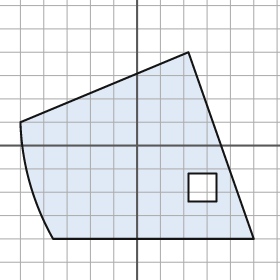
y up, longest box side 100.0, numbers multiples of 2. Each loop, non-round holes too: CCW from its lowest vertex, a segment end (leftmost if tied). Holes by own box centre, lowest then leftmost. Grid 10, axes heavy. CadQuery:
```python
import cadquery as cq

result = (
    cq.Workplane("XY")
    .moveTo(-36.0, -40.0)
    .lineTo(50.0, -40.0)
    .lineTo(22.0, 40.0)
    .lineTo(-50.0, 10.0)
    .threePointArc((-46.0, -16.0), (-36.0, -40.0))
    .close()
    .moveTo(22.0, -24.0)
    .lineTo(34.0, -24.0)
    .lineTo(34.0, -12.0)
    .lineTo(22.0, -12.0)
    .close()
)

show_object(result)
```